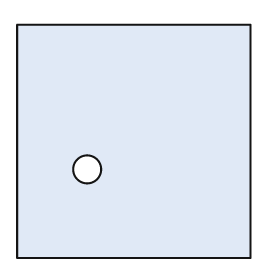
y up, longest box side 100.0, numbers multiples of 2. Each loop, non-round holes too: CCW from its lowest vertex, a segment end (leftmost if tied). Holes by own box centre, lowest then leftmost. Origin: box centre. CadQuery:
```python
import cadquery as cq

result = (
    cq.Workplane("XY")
    .moveTo(-50.0, -50.0)
    .lineTo(50.0, -50.0)
    .lineTo(50.0, 50.0)
    .lineTo(-50.0, 50.0)
    .close()
    .moveTo(-20.0, -12.0)
    .circle(6.0)
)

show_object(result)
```